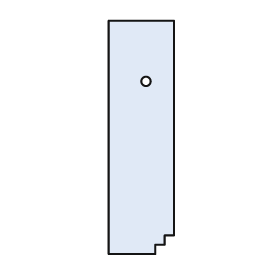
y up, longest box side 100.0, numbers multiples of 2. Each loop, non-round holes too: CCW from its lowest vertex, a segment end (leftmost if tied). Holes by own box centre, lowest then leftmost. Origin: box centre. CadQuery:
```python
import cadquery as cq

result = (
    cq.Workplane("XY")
    .moveTo(-14.0, -50.0)
    .lineTo(6.0, -50.0)
    .lineTo(6.0, -46.0)
    .lineTo(10.0, -46.0)
    .lineTo(10.0, -42.0)
    .lineTo(14.0, -42.0)
    .lineTo(14.0, 50.0)
    .lineTo(-14.0, 50.0)
    .close()
    .moveTo(2.0, 24.0)
    .circle(2.0)
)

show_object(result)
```